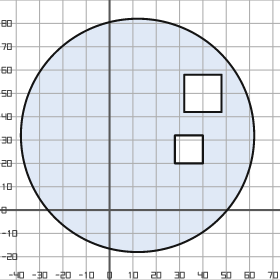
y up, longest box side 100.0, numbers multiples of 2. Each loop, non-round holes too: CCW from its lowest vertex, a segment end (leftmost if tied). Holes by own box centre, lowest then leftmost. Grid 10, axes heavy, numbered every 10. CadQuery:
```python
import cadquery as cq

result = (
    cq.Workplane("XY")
    .moveTo(12.0, 32.0)
    .circle(50.0)
    .moveTo(28.0, 20.0)
    .lineTo(40.0, 20.0)
    .lineTo(40.0, 32.0)
    .lineTo(28.0, 32.0)
    .close()
    .moveTo(32.0, 42.0)
    .lineTo(48.0, 42.0)
    .lineTo(48.0, 58.0)
    .lineTo(32.0, 58.0)
    .close()
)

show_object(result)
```